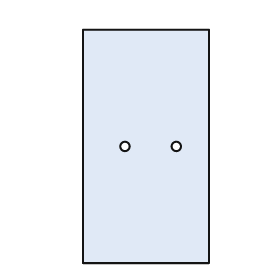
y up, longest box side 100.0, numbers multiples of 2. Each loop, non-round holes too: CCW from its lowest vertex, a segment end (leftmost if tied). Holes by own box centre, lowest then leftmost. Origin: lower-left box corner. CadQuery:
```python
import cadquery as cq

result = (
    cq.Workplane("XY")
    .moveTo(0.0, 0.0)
    .lineTo(54.0, 0.0)
    .lineTo(54.0, 100.0)
    .lineTo(0.0, 100.0)
    .close()
    .moveTo(18.0, 50.0)
    .circle(2.0)
    .moveTo(40.0, 50.0)
    .circle(2.0)
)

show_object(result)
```